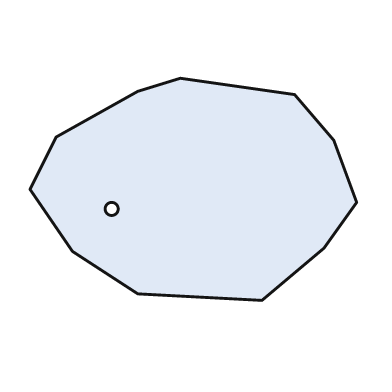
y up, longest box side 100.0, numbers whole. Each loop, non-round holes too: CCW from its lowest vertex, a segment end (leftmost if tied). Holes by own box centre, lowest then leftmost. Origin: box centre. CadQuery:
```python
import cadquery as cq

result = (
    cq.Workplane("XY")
    .moveTo(21.0, -34.0)
    .lineTo(40.0, -18.0)
    .lineTo(50.0, -4.0)
    .lineTo(43.0, 15.0)
    .lineTo(31.0, 29.0)
    .lineTo(-4.0, 34.0)
    .lineTo(-17.0, 30.0)
    .lineTo(-42.0, 16.0)
    .lineTo(-50.0, 0.0)
    .lineTo(-37.0, -19.0)
    .lineTo(-17.0, -32.0)
    .close()
    .moveTo(-25.0, -6.0)
    .circle(2.0)
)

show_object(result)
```